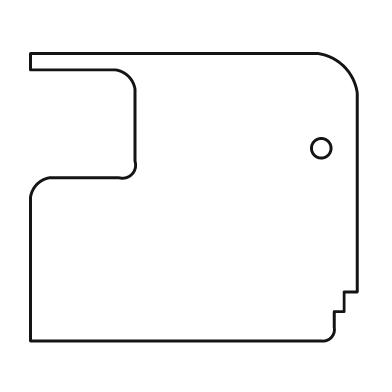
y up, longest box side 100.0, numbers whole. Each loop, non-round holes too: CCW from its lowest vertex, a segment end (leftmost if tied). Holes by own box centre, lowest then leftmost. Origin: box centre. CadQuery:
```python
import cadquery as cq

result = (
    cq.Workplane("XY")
    .moveTo(-50.0, -44.0)
    .lineTo(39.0, -44.0)
    .threePointArc((42.0, -43.0), (43.0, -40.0))
    .lineTo(43.0, -35.0)
    .lineTo(46.0, -35.0)
    .lineTo(46.0, -29.0)
    .lineTo(50.0, -29.0)
    .lineTo(50.0, 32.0)
    .threePointArc((46.0, 40.0), (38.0, 44.0))
    .lineTo(-50.0, 44.0)
    .lineTo(-50.0, 39.0)
    .lineTo(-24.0, 39.0)
    .threePointArc((-20.0, 37.0), (-18.0, 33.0))
    .lineTo(-18.0, 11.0)
    .threePointArc((-19.0, 7.0), (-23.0, 6.0))
    .lineTo(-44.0, 6.0)
    .threePointArc((-48.0, 4.0), (-50.0, 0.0))
    .close()
    .moveTo(39.0, 15.0)
    .circle(3.0)
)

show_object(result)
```